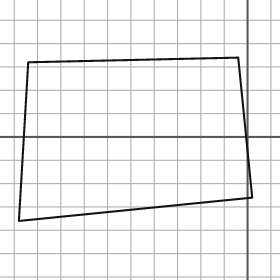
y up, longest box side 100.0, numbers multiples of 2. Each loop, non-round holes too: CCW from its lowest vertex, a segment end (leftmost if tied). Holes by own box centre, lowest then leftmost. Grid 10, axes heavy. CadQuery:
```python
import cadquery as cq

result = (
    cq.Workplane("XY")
    .moveTo(-98.0, -36.0)
    .lineTo(2.0, -26.0)
    .lineTo(-4.0, 34.0)
    .lineTo(-94.0, 32.0)
    .close()
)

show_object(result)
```